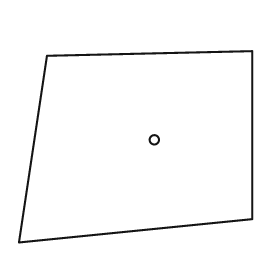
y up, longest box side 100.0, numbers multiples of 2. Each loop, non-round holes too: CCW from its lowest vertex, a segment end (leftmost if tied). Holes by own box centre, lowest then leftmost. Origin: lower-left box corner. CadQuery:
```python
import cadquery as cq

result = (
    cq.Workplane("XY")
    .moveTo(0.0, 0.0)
    .lineTo(100.0, 10.0)
    .lineTo(100.0, 82.0)
    .lineTo(12.0, 80.0)
    .close()
    .moveTo(58.0, 44.0)
    .circle(2.0)
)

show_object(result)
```